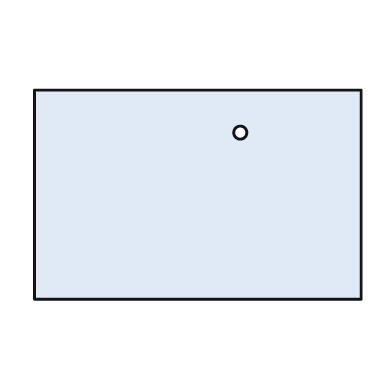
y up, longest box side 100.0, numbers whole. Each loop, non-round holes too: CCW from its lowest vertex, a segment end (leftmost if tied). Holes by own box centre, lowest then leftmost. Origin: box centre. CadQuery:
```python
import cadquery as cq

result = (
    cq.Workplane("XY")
    .moveTo(-50.0, -32.0)
    .lineTo(50.0, -32.0)
    .lineTo(50.0, 32.0)
    .lineTo(-50.0, 32.0)
    .close()
    .moveTo(13.0, 19.0)
    .circle(2.0)
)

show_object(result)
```